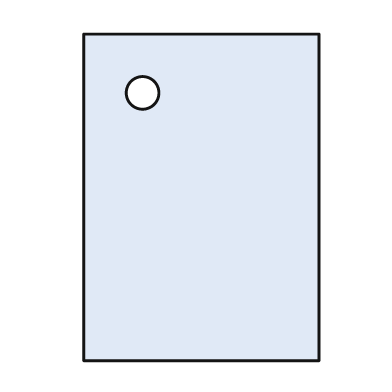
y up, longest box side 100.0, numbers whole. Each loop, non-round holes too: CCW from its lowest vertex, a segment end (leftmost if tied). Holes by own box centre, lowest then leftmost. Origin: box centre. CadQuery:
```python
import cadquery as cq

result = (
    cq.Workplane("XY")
    .moveTo(-36.0, -50.0)
    .lineTo(36.0, -50.0)
    .lineTo(36.0, 50.0)
    .lineTo(-36.0, 50.0)
    .close()
    .moveTo(-18.0, 32.0)
    .circle(5.0)
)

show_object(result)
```